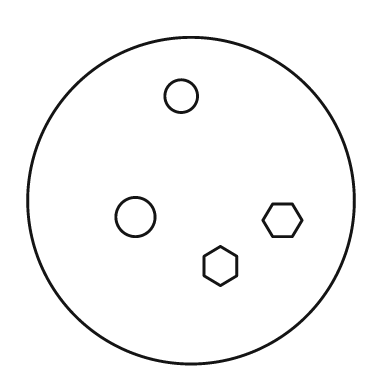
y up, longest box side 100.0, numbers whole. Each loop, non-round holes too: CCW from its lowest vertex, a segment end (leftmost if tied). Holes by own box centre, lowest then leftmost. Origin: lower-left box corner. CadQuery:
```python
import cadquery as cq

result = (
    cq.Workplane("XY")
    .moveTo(50.0, 50.0)
    .circle(50.0)
    .moveTo(59.0, 24.0)
    .lineTo(64.0, 27.0)
    .lineTo(64.0, 33.0)
    .lineTo(59.0, 36.0)
    .lineTo(54.0, 33.0)
    .lineTo(54.0, 27.0)
    .close()
    .moveTo(75.0, 39.0)
    .lineTo(81.0, 39.0)
    .lineTo(84.0, 44.0)
    .lineTo(81.0, 49.0)
    .lineTo(75.0, 49.0)
    .lineTo(72.0, 44.0)
    .close()
    .moveTo(33.0, 45.0)
    .circle(6.0)
    .moveTo(47.0, 82.0)
    .circle(5.0)
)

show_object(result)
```